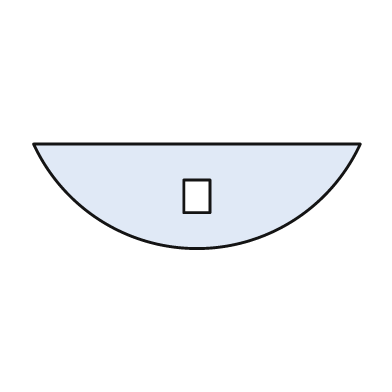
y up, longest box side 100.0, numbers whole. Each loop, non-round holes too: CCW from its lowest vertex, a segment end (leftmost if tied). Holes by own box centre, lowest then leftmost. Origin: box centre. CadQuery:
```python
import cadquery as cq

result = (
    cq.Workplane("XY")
    .moveTo(-50.0, 16.0)
    .threePointArc((0.0, -16.0), (50.0, 16.0))
    .close()
    .moveTo(-4.0, -5.0)
    .lineTo(4.0, -5.0)
    .lineTo(4.0, 5.0)
    .lineTo(-4.0, 5.0)
    .close()
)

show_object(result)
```